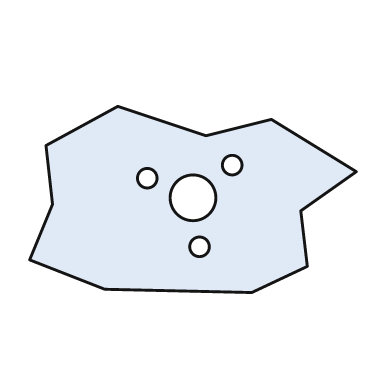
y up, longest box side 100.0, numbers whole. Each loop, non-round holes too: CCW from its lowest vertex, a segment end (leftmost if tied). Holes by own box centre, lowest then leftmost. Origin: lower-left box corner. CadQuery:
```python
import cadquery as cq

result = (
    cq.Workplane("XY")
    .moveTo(68.0, 0.0)
    .lineTo(85.0, 8.0)
    .lineTo(83.0, 25.0)
    .lineTo(100.0, 37.0)
    .lineTo(74.0, 53.0)
    .lineTo(54.0, 48.0)
    .lineTo(27.0, 57.0)
    .lineTo(5.0, 45.0)
    .lineTo(7.0, 27.0)
    .lineTo(0.0, 10.0)
    .lineTo(23.0, 1.0)
    .close()
    .moveTo(52.0, 14.0)
    .circle(3.0)
    .moveTo(50.0, 29.0)
    .circle(7.0)
    .moveTo(36.0, 35.0)
    .circle(3.0)
    .moveTo(62.0, 39.0)
    .circle(3.0)
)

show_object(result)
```